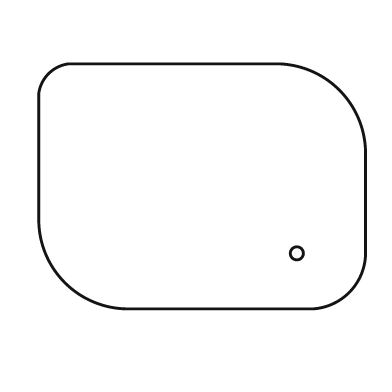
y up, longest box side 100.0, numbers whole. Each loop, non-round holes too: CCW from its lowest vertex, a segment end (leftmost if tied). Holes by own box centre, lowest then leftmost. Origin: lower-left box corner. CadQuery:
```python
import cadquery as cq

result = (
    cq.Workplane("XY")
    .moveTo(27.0, 0.0)
    .lineTo(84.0, 0.0)
    .threePointArc((95.0, 5.0), (100.0, 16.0))
    .lineTo(100.0, 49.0)
    .threePointArc((92.0, 67.0), (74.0, 75.0))
    .lineTo(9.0, 75.0)
    .threePointArc((3.0, 72.0), (0.0, 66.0))
    .lineTo(0.0, 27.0)
    .threePointArc((8.0, 8.0), (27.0, 0.0))
    .close()
    .moveTo(79.0, 17.0)
    .circle(2.0)
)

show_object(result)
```